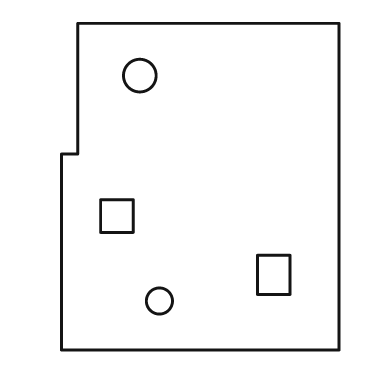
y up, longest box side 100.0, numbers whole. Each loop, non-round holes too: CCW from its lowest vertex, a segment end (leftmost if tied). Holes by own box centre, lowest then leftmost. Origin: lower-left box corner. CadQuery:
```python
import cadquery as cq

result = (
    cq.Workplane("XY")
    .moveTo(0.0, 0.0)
    .lineTo(85.0, 0.0)
    .lineTo(85.0, 100.0)
    .lineTo(5.0, 100.0)
    .lineTo(5.0, 60.0)
    .lineTo(0.0, 60.0)
    .close()
    .moveTo(30.0, 15.0)
    .circle(4.0)
    .moveTo(60.0, 17.0)
    .lineTo(70.0, 17.0)
    .lineTo(70.0, 29.0)
    .lineTo(60.0, 29.0)
    .close()
    .moveTo(12.0, 36.0)
    .lineTo(22.0, 36.0)
    .lineTo(22.0, 46.0)
    .lineTo(12.0, 46.0)
    .close()
    .moveTo(24.0, 84.0)
    .circle(5.0)
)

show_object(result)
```